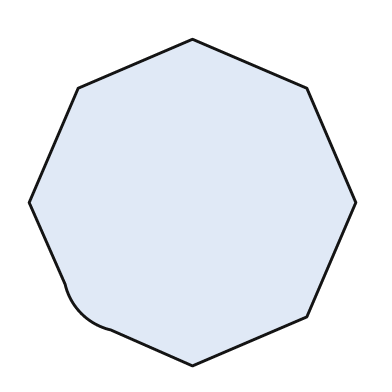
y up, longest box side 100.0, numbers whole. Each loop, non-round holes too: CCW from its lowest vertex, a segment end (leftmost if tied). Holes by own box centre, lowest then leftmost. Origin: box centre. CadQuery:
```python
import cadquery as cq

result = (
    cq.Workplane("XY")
    .moveTo(0.0, -50.0)
    .lineTo(35.0, -35.0)
    .lineTo(50.0, 0.0)
    .lineTo(35.0, 35.0)
    .lineTo(0.0, 50.0)
    .lineTo(-35.0, 35.0)
    .lineTo(-50.0, 0.0)
    .lineTo(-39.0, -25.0)
    .threePointArc((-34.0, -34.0), (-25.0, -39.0))
    .close()
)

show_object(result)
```